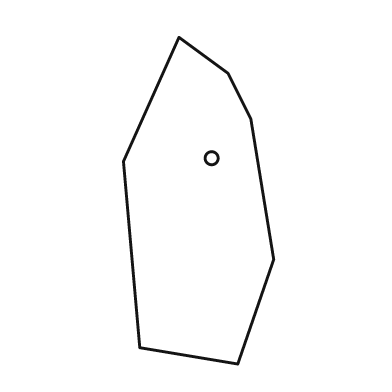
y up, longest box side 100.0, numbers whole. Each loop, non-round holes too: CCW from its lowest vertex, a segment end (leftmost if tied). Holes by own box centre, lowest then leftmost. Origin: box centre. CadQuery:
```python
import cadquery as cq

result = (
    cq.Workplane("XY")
    .moveTo(12.0, -50.0)
    .lineTo(23.0, -18.0)
    .lineTo(16.0, 25.0)
    .lineTo(9.0, 39.0)
    .lineTo(-6.0, 50.0)
    .lineTo(-23.0, 12.0)
    .lineTo(-18.0, -45.0)
    .close()
    .moveTo(4.0, 13.0)
    .circle(2.0)
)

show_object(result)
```